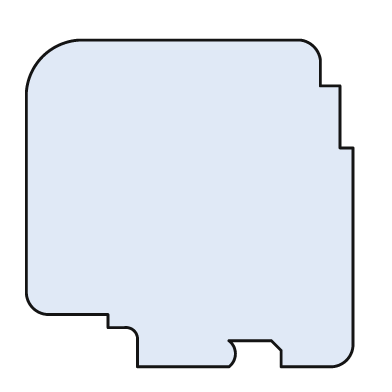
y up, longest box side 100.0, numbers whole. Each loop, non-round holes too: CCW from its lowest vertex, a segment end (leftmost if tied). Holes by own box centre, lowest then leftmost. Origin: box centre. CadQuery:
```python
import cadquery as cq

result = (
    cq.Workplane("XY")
    .moveTo(-16.0, -50.0)
    .lineTo(12.0, -50.0)
    .threePointArc((14.0, -46.0), (12.0, -42.0))
    .lineTo(25.0, -42.0)
    .lineTo(28.0, -45.0)
    .lineTo(28.0, -50.0)
    .lineTo(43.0, -50.0)
    .threePointArc((48.0, -48.0), (50.0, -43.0))
    .lineTo(50.0, 17.0)
    .lineTo(46.0, 17.0)
    .lineTo(46.0, 36.0)
    .lineTo(40.0, 36.0)
    .lineTo(40.0, 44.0)
    .threePointArc((38.0, 48.0), (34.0, 50.0))
    .lineTo(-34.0, 50.0)
    .threePointArc((-45.0, 45.0), (-50.0, 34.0))
    .lineTo(-50.0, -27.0)
    .threePointArc((-48.0, -32.0), (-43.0, -34.0))
    .lineTo(-25.0, -34.0)
    .lineTo(-25.0, -38.0)
    .lineTo(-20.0, -38.0)
    .threePointArc((-17.0, -39.0), (-16.0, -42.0))
    .close()
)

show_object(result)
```